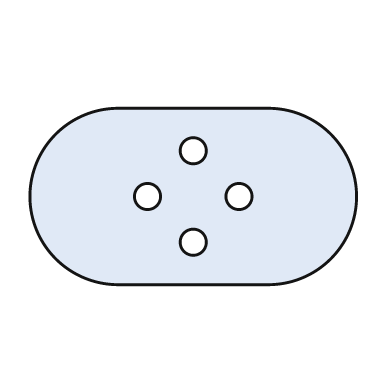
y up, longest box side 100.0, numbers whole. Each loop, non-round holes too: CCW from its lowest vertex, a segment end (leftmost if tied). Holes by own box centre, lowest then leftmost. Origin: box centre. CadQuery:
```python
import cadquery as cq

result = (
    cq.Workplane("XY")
    .moveTo(-23.0, -27.0)
    .lineTo(23.0, -27.0)
    .threePointArc((50.0, 0.0), (23.0, 27.0))
    .lineTo(-23.0, 27.0)
    .threePointArc((-50.0, 0.0), (-23.0, -27.0))
    .close()
    .moveTo(0.0, -14.0)
    .circle(4.0)
    .moveTo(-14.0, 0.0)
    .circle(4.0)
    .moveTo(14.0, 0.0)
    .circle(4.0)
    .moveTo(0.0, 14.0)
    .circle(4.0)
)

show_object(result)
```